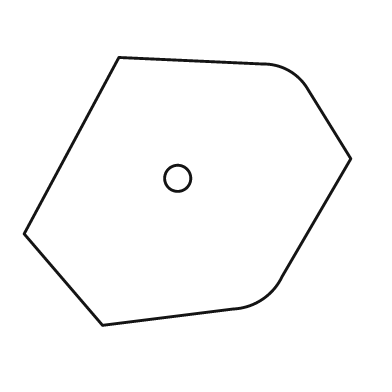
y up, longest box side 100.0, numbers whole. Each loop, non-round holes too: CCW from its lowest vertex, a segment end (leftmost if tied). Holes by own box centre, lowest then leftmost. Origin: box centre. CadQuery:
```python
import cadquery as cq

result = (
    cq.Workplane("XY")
    .moveTo(-26.0, -41.0)
    .lineTo(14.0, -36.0)
    .threePointArc((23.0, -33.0), (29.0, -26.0))
    .lineTo(50.0, 10.0)
    .lineTo(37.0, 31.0)
    .threePointArc((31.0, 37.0), (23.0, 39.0))
    .lineTo(-21.0, 41.0)
    .lineTo(-50.0, -13.0)
    .close()
    .moveTo(-3.0, 4.0)
    .circle(4.0)
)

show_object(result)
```